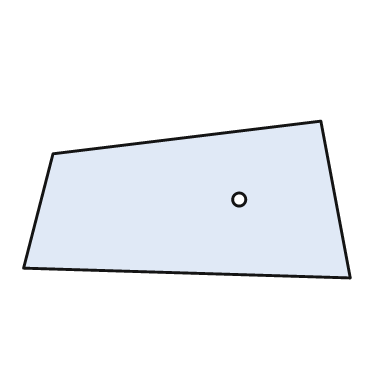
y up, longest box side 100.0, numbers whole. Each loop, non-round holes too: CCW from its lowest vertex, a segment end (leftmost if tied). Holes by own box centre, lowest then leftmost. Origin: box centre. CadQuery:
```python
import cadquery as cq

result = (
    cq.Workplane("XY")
    .moveTo(50.0, -24.0)
    .lineTo(41.0, 24.0)
    .lineTo(-41.0, 14.0)
    .lineTo(-50.0, -21.0)
    .close()
    .moveTo(16.0, 0.0)
    .circle(2.0)
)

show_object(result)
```